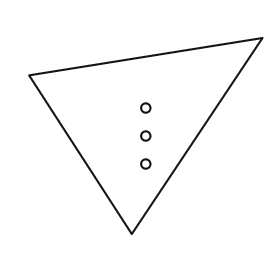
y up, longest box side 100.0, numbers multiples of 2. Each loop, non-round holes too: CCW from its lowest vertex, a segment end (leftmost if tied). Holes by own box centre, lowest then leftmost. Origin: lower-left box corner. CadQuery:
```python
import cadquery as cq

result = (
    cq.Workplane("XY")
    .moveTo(44.0, 0.0)
    .lineTo(100.0, 84.0)
    .lineTo(0.0, 68.0)
    .close()
    .moveTo(50.0, 30.0)
    .circle(2.0)
    .moveTo(50.0, 42.0)
    .circle(2.0)
    .moveTo(50.0, 54.0)
    .circle(2.0)
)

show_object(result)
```